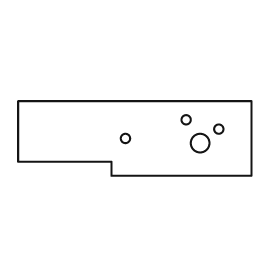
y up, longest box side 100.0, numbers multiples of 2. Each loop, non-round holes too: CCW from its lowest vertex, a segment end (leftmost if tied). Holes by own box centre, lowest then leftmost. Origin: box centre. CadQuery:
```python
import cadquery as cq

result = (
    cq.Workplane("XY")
    .moveTo(-10.0, -16.0)
    .lineTo(50.0, -16.0)
    .lineTo(50.0, 16.0)
    .lineTo(-50.0, 16.0)
    .lineTo(-50.0, -10.0)
    .lineTo(-10.0, -10.0)
    .close()
    .moveTo(28.0, -2.0)
    .circle(4.0)
    .moveTo(-4.0, 0.0)
    .circle(2.0)
    .moveTo(36.0, 4.0)
    .circle(2.0)
    .moveTo(22.0, 8.0)
    .circle(2.0)
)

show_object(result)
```